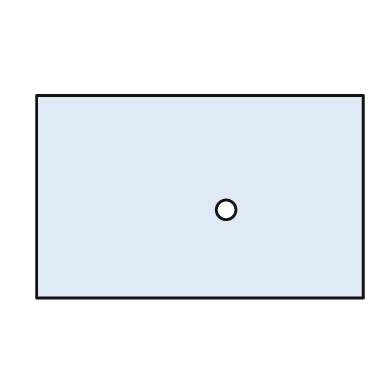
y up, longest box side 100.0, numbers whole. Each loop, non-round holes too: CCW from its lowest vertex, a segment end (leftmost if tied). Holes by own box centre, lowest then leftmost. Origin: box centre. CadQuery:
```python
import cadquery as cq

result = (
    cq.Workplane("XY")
    .moveTo(-50.0, -31.0)
    .lineTo(50.0, -31.0)
    .lineTo(50.0, 31.0)
    .lineTo(-50.0, 31.0)
    .close()
    .moveTo(8.0, -4.0)
    .circle(3.0)
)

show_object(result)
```